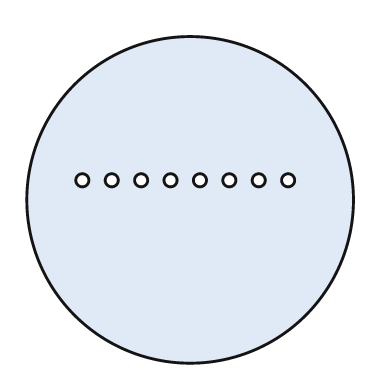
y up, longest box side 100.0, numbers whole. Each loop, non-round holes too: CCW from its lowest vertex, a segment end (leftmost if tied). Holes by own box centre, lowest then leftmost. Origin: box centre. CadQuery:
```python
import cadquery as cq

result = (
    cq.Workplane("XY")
    .moveTo(0.0, 0.0)
    .circle(50.0)
    .moveTo(-33.0, 6.0)
    .circle(2.0)
    .moveTo(-24.0, 6.0)
    .circle(2.0)
    .moveTo(-15.0, 6.0)
    .circle(2.0)
    .moveTo(-6.0, 6.0)
    .circle(2.0)
    .moveTo(3.0, 6.0)
    .circle(2.0)
    .moveTo(12.0, 6.0)
    .circle(2.0)
    .moveTo(21.0, 6.0)
    .circle(2.0)
    .moveTo(30.0, 6.0)
    .circle(2.0)
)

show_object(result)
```